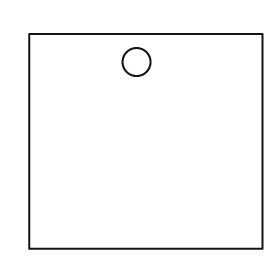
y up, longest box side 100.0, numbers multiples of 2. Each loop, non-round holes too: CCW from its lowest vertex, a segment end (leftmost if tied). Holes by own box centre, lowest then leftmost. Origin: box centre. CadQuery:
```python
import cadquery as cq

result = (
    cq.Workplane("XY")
    .moveTo(-50.0, -46.0)
    .lineTo(50.0, -46.0)
    .lineTo(50.0, 46.0)
    .lineTo(-50.0, 46.0)
    .close()
    .moveTo(-4.0, 34.0)
    .circle(6.0)
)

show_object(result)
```